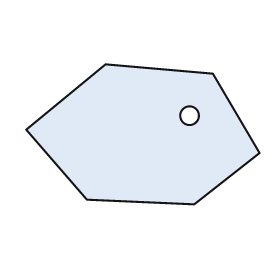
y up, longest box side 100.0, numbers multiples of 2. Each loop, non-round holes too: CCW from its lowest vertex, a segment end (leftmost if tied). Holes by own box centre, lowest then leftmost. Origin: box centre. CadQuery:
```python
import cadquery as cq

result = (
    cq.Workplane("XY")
    .moveTo(22.0, -30.0)
    .lineTo(50.0, -8.0)
    .lineTo(30.0, 26.0)
    .lineTo(-16.0, 30.0)
    .lineTo(-50.0, 2.0)
    .lineTo(-24.0, -28.0)
    .close()
    .moveTo(20.0, 8.0)
    .circle(4.0)
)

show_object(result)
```